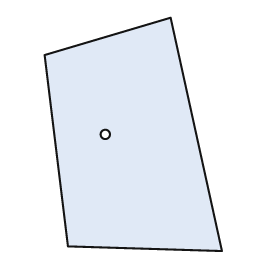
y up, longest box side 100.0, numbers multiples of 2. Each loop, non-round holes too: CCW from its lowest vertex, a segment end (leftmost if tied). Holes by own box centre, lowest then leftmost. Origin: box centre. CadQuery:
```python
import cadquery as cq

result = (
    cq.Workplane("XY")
    .moveTo(38.0, -50.0)
    .lineTo(16.0, 50.0)
    .lineTo(-38.0, 34.0)
    .lineTo(-28.0, -48.0)
    .close()
    .moveTo(-12.0, 0.0)
    .circle(2.0)
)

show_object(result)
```